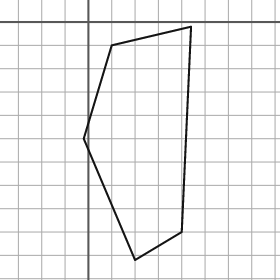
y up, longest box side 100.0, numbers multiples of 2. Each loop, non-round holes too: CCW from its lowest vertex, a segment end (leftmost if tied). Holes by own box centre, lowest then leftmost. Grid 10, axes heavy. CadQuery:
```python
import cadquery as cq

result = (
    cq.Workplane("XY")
    .moveTo(20.0, -102.0)
    .lineTo(40.0, -90.0)
    .lineTo(44.0, -2.0)
    .lineTo(10.0, -10.0)
    .lineTo(-2.0, -50.0)
    .close()
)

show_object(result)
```